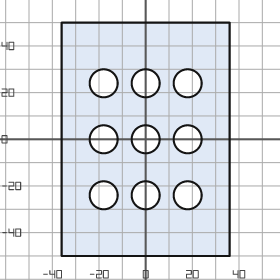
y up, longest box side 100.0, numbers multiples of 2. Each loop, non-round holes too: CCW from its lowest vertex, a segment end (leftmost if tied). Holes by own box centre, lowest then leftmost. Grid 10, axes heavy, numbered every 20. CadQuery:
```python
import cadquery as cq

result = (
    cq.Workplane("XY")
    .moveTo(-36.0, -50.0)
    .lineTo(36.0, -50.0)
    .lineTo(36.0, 50.0)
    .lineTo(-36.0, 50.0)
    .close()
    .moveTo(-18.0, -24.0)
    .circle(6.0)
    .moveTo(0.0, -24.0)
    .circle(6.0)
    .moveTo(18.0, -24.0)
    .circle(6.0)
    .moveTo(-18.0, 0.0)
    .circle(6.0)
    .moveTo(0.0, 0.0)
    .circle(6.0)
    .moveTo(18.0, 0.0)
    .circle(6.0)
    .moveTo(-18.0, 24.0)
    .circle(6.0)
    .moveTo(0.0, 24.0)
    .circle(6.0)
    .moveTo(18.0, 24.0)
    .circle(6.0)
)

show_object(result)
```